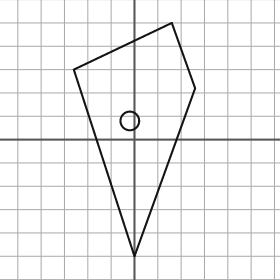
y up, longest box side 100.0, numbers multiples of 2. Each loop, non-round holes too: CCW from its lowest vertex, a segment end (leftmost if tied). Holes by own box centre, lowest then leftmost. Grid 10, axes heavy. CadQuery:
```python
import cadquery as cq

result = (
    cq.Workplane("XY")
    .moveTo(0.0, -50.0)
    .lineTo(26.0, 22.0)
    .lineTo(16.0, 50.0)
    .lineTo(-26.0, 30.0)
    .close()
    .moveTo(-2.0, 8.0)
    .circle(4.0)
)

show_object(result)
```